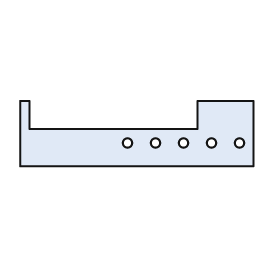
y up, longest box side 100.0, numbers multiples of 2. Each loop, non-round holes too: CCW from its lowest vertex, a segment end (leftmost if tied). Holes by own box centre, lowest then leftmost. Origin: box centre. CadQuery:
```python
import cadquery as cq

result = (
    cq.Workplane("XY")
    .moveTo(-50.0, -14.0)
    .lineTo(50.0, -14.0)
    .lineTo(50.0, 14.0)
    .lineTo(26.0, 14.0)
    .lineTo(26.0, 2.0)
    .lineTo(-46.0, 2.0)
    .lineTo(-46.0, 14.0)
    .lineTo(-50.0, 14.0)
    .close()
    .moveTo(-4.0, -4.0)
    .circle(2.0)
    .moveTo(8.0, -4.0)
    .circle(2.0)
    .moveTo(20.0, -4.0)
    .circle(2.0)
    .moveTo(32.0, -4.0)
    .circle(2.0)
    .moveTo(44.0, -4.0)
    .circle(2.0)
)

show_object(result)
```